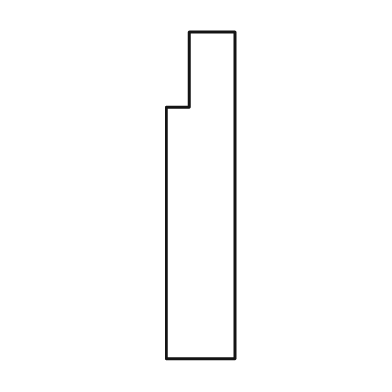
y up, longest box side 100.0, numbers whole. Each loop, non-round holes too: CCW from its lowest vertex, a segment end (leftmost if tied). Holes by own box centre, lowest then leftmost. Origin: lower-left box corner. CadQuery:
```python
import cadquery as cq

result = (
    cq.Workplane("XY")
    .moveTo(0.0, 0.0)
    .lineTo(21.0, 0.0)
    .lineTo(21.0, 100.0)
    .lineTo(7.0, 100.0)
    .lineTo(7.0, 77.0)
    .lineTo(0.0, 77.0)
    .close()
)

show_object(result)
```